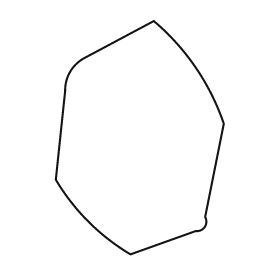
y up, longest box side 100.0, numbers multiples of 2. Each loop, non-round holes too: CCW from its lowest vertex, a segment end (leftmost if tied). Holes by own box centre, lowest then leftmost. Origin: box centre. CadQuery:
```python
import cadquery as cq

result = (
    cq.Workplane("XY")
    .moveTo(-4.0, -50.0)
    .lineTo(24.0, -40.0)
    .threePointArc((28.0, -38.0), (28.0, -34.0))
    .lineTo(36.0, 6.0)
    .threePointArc((24.0, 30.0), (6.0, 50.0))
    .lineTo(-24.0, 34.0)
    .threePointArc((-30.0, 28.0), (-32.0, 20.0))
    .lineTo(-36.0, -18.0)
    .threePointArc((-22.0, -36.0), (-4.0, -50.0))
    .close()
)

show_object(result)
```